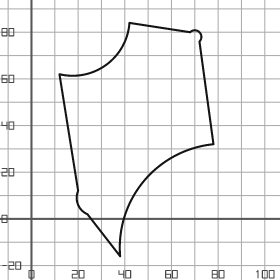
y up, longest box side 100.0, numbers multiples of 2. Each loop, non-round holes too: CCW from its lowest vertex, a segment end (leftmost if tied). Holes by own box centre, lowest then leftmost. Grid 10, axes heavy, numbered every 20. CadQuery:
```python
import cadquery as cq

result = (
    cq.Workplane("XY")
    .moveTo(38.0, -16.0)
    .threePointArc((48.0, 16.0), (78.0, 32.0))
    .lineTo(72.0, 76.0)
    .threePointArc((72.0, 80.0), (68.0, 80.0))
    .lineTo(42.0, 84.0)
    .threePointArc((32.0, 66.0), (12.0, 62.0))
    .lineTo(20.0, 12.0)
    .threePointArc((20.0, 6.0), (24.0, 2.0))
    .close()
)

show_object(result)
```